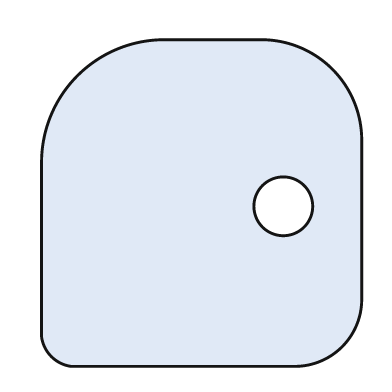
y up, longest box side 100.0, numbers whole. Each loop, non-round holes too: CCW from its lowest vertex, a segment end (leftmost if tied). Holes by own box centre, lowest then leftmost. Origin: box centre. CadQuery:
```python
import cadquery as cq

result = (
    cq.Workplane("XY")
    .moveTo(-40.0, -50.0)
    .lineTo(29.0, -50.0)
    .threePointArc((43.0, -44.0), (49.0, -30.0))
    .lineTo(49.0, 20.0)
    .threePointArc((40.0, 41.0), (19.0, 50.0))
    .lineTo(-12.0, 50.0)
    .threePointArc((-38.0, 39.0), (-49.0, 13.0))
    .lineTo(-49.0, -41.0)
    .threePointArc((-46.0, -47.0), (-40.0, -50.0))
    .close()
    .moveTo(25.0, -1.0)
    .circle(9.0)
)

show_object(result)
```